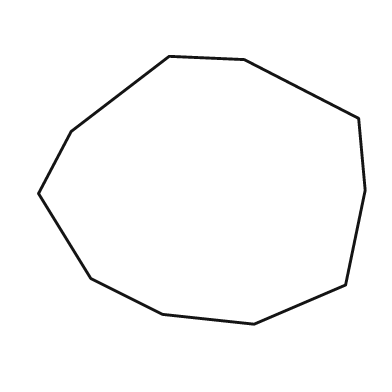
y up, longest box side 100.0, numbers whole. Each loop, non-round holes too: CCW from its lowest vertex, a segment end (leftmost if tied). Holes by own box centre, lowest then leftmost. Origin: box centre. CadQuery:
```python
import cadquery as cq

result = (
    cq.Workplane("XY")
    .moveTo(16.0, -41.0)
    .lineTo(44.0, -29.0)
    .lineTo(50.0, 0.0)
    .lineTo(48.0, 22.0)
    .lineTo(13.0, 40.0)
    .lineTo(-10.0, 41.0)
    .lineTo(-40.0, 18.0)
    .lineTo(-50.0, -1.0)
    .lineTo(-34.0, -27.0)
    .lineTo(-12.0, -38.0)
    .close()
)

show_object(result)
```